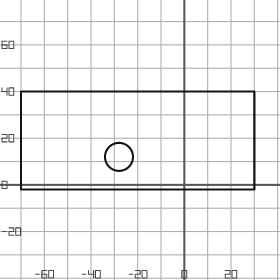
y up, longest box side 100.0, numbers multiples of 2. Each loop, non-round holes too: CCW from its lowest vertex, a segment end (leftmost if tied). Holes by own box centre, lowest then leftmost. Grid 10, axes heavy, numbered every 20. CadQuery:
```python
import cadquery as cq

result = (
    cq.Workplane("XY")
    .moveTo(-70.0, -2.0)
    .lineTo(30.0, -2.0)
    .lineTo(30.0, 40.0)
    .lineTo(-70.0, 40.0)
    .close()
    .moveTo(-28.0, 12.0)
    .circle(6.0)
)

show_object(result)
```